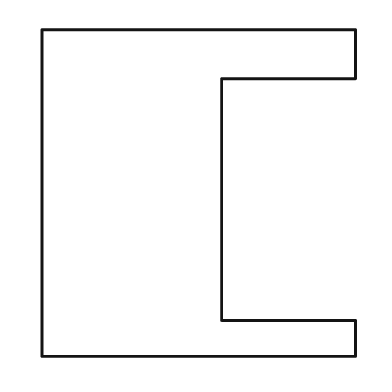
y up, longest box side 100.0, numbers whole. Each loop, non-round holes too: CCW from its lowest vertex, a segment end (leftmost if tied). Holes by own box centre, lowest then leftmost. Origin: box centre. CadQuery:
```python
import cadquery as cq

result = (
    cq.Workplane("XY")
    .moveTo(-48.0, -50.0)
    .lineTo(48.0, -50.0)
    .lineTo(48.0, -39.0)
    .lineTo(7.0, -39.0)
    .lineTo(7.0, 35.0)
    .lineTo(48.0, 35.0)
    .lineTo(48.0, 50.0)
    .lineTo(-48.0, 50.0)
    .close()
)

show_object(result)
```